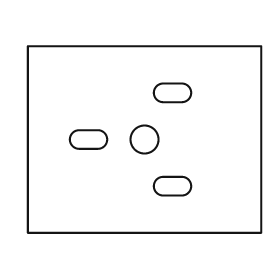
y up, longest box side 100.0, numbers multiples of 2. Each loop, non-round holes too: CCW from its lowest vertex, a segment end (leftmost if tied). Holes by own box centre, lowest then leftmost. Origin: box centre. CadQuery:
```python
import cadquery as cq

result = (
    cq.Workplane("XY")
    .moveTo(-50.0, -40.0)
    .lineTo(50.0, -40.0)
    .lineTo(50.0, 40.0)
    .lineTo(-50.0, 40.0)
    .close()
    .moveTo(8.0, -24.0)
    .lineTo(16.0, -24.0)
    .threePointArc((20.0, -20.0), (16.0, -16.0))
    .lineTo(8.0, -16.0)
    .threePointArc((4.0, -20.0), (8.0, -24.0))
    .close()
    .moveTo(-28.0, -4.0)
    .lineTo(-20.0, -4.0)
    .threePointArc((-16.0, 0.0), (-20.0, 4.0))
    .lineTo(-28.0, 4.0)
    .threePointArc((-32.0, 0.0), (-28.0, -4.0))
    .close()
    .moveTo(0.0, 0.0)
    .circle(6.0)
    .moveTo(8.0, 16.0)
    .lineTo(16.0, 16.0)
    .threePointArc((20.0, 20.0), (16.0, 24.0))
    .lineTo(8.0, 24.0)
    .threePointArc((4.0, 20.0), (8.0, 16.0))
    .close()
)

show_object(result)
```